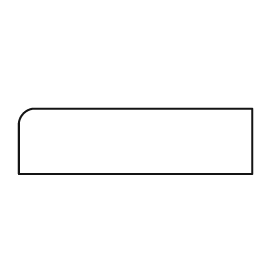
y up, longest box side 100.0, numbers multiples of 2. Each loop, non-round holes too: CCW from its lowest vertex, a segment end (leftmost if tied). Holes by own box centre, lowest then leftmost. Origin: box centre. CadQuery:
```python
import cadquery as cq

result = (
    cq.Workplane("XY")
    .moveTo(-50.0, -14.0)
    .lineTo(50.0, -14.0)
    .lineTo(50.0, 14.0)
    .lineTo(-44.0, 14.0)
    .threePointArc((-48.0, 12.0), (-50.0, 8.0))
    .close()
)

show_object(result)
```